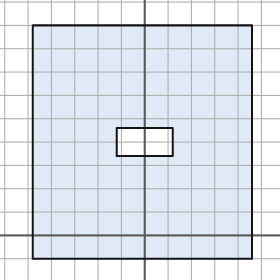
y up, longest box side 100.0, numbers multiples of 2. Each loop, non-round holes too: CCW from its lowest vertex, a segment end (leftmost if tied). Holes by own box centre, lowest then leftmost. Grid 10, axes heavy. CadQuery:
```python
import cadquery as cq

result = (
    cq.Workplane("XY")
    .moveTo(-48.0, -10.0)
    .lineTo(46.0, -10.0)
    .lineTo(46.0, 90.0)
    .lineTo(-48.0, 90.0)
    .close()
    .moveTo(-12.0, 34.0)
    .lineTo(12.0, 34.0)
    .lineTo(12.0, 46.0)
    .lineTo(-12.0, 46.0)
    .close()
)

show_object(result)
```